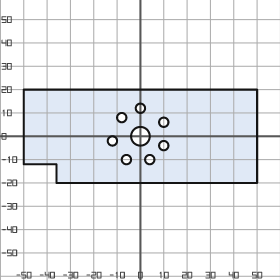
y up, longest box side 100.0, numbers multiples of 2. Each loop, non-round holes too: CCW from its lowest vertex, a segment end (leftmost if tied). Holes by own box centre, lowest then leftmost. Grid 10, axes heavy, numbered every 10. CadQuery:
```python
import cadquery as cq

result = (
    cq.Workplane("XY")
    .moveTo(-36.0, -20.0)
    .lineTo(50.0, -20.0)
    .lineTo(50.0, 20.0)
    .lineTo(-50.0, 20.0)
    .lineTo(-50.0, -12.0)
    .lineTo(-36.0, -12.0)
    .close()
    .moveTo(-6.0, -10.0)
    .circle(2.0)
    .moveTo(4.0, -10.0)
    .circle(2.0)
    .moveTo(10.0, -4.0)
    .circle(2.0)
    .moveTo(-12.0, -2.0)
    .circle(2.0)
    .moveTo(0.0, 0.0)
    .circle(4.0)
    .moveTo(10.0, 6.0)
    .circle(2.0)
    .moveTo(-8.0, 8.0)
    .circle(2.0)
    .moveTo(0.0, 12.0)
    .circle(2.0)
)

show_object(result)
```